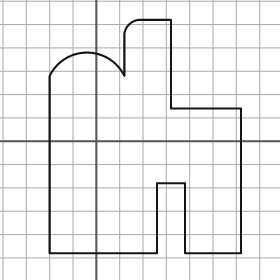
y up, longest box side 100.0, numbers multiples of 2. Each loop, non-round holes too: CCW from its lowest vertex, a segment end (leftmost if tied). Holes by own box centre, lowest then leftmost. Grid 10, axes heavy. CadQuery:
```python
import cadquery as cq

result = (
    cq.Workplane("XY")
    .moveTo(-20.0, -48.0)
    .lineTo(26.0, -48.0)
    .lineTo(26.0, -18.0)
    .lineTo(38.0, -18.0)
    .lineTo(38.0, -48.0)
    .lineTo(62.0, -48.0)
    .lineTo(62.0, 14.0)
    .lineTo(32.0, 14.0)
    .lineTo(32.0, 52.0)
    .lineTo(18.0, 52.0)
    .threePointArc((14.0, 50.0), (12.0, 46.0))
    .lineTo(12.0, 28.0)
    .threePointArc((-4.0, 38.0), (-20.0, 28.0))
    .close()
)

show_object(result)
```